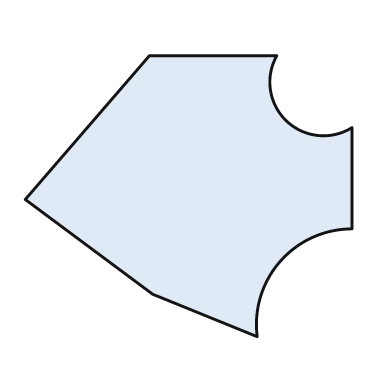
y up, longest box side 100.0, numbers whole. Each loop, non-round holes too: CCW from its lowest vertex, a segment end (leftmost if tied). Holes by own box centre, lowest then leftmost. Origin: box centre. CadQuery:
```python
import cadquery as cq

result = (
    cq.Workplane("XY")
    .moveTo(21.0, -43.0)
    .threePointArc((28.0, -20.0), (50.0, -10.0))
    .lineTo(50.0, 21.0)
    .threePointArc((30.0, 23.0), (27.0, 43.0))
    .lineTo(-12.0, 43.0)
    .lineTo(-50.0, -1.0)
    .lineTo(-11.0, -30.0)
    .close()
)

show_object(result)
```